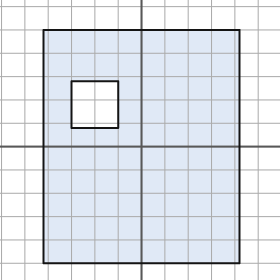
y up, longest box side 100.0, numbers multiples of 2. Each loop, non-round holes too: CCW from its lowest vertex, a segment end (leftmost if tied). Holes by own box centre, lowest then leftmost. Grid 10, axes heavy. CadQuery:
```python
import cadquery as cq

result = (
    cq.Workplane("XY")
    .moveTo(-42.0, -50.0)
    .lineTo(42.0, -50.0)
    .lineTo(42.0, 50.0)
    .lineTo(-42.0, 50.0)
    .close()
    .moveTo(-30.0, 8.0)
    .lineTo(-10.0, 8.0)
    .lineTo(-10.0, 28.0)
    .lineTo(-30.0, 28.0)
    .close()
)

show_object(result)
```